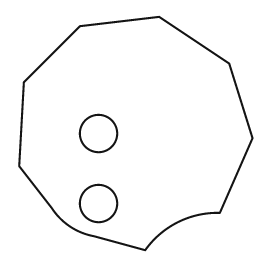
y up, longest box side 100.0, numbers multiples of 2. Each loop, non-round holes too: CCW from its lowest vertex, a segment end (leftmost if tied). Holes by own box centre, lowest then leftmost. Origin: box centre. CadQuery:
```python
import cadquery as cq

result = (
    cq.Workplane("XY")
    .moveTo(4.0, -50.0)
    .threePointArc((18.0, -38.0), (36.0, -34.0))
    .lineTo(50.0, -2.0)
    .lineTo(40.0, 30.0)
    .lineTo(10.0, 50.0)
    .lineTo(-24.0, 46.0)
    .lineTo(-48.0, 22.0)
    .lineTo(-50.0, -14.0)
    .lineTo(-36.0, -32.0)
    .threePointArc((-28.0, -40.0), (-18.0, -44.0))
    .close()
    .moveTo(-16.0, -30.0)
    .circle(8.0)
    .moveTo(-16.0, 0.0)
    .circle(8.0)
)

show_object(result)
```